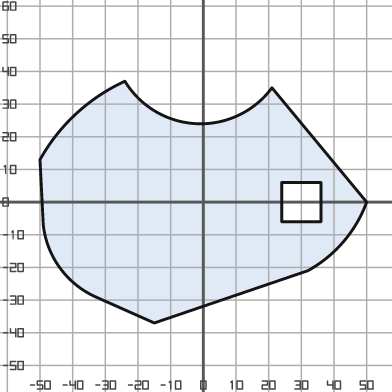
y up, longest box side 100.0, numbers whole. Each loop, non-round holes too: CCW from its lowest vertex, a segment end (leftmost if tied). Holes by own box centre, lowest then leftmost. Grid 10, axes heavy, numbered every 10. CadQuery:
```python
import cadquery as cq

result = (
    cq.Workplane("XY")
    .moveTo(-15.0, -37.0)
    .lineTo(32.0, -21.0)
    .threePointArc((43.0, -12.0), (50.0, 0.0))
    .lineTo(21.0, 35.0)
    .threePointArc((-2.0, 24.0), (-24.0, 37.0))
    .threePointArc((-39.0, 27.0), (-50.0, 13.0))
    .lineTo(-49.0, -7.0)
    .threePointArc((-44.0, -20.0), (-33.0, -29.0))
    .close()
    .moveTo(24.0, -6.0)
    .lineTo(36.0, -6.0)
    .lineTo(36.0, 6.0)
    .lineTo(24.0, 6.0)
    .close()
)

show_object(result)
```